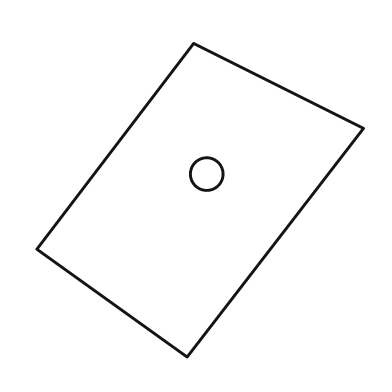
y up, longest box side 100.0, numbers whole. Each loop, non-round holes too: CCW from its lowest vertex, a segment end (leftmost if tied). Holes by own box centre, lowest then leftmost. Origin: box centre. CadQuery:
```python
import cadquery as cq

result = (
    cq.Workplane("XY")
    .moveTo(-4.0, -48.0)
    .lineTo(50.0, 22.0)
    .lineTo(-2.0, 48.0)
    .lineTo(-50.0, -15.0)
    .close()
    .moveTo(2.0, 8.0)
    .circle(5.0)
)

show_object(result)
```